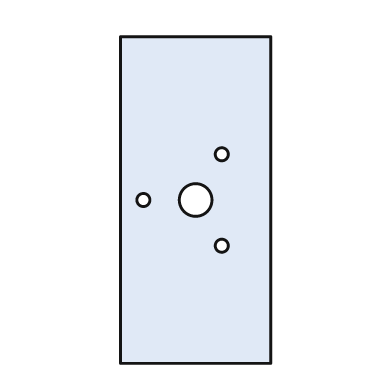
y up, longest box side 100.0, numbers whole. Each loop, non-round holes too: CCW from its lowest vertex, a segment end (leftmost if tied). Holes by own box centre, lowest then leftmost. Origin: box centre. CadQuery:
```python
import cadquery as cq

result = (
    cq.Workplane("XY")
    .moveTo(-23.0, -50.0)
    .lineTo(23.0, -50.0)
    .lineTo(23.0, 50.0)
    .lineTo(-23.0, 50.0)
    .close()
    .moveTo(8.0, -14.0)
    .circle(2.0)
    .moveTo(-16.0, 0.0)
    .circle(2.0)
    .moveTo(0.0, 0.0)
    .circle(5.0)
    .moveTo(8.0, 14.0)
    .circle(2.0)
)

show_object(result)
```